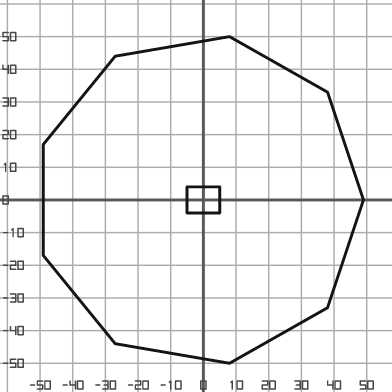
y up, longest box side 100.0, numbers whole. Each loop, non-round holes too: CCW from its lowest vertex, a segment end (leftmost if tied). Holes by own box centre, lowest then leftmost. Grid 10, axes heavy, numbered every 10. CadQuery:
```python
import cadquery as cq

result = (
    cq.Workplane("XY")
    .moveTo(8.0, -50.0)
    .lineTo(38.0, -33.0)
    .lineTo(49.0, 0.0)
    .lineTo(38.0, 33.0)
    .lineTo(8.0, 50.0)
    .lineTo(-27.0, 44.0)
    .lineTo(-49.0, 17.0)
    .lineTo(-49.0, -17.0)
    .lineTo(-27.0, -44.0)
    .close()
    .moveTo(-5.0, -4.0)
    .lineTo(5.0, -4.0)
    .lineTo(5.0, 4.0)
    .lineTo(-5.0, 4.0)
    .close()
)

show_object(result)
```